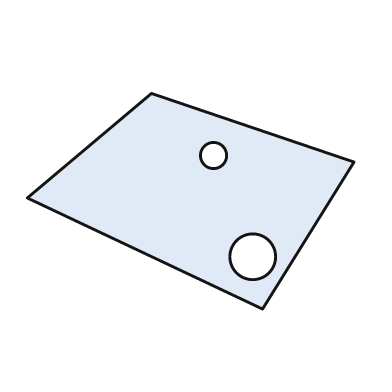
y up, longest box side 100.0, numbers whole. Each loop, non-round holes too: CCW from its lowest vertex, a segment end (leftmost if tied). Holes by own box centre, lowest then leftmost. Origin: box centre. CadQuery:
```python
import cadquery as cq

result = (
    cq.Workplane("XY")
    .moveTo(22.0, -33.0)
    .lineTo(50.0, 12.0)
    .lineTo(-12.0, 33.0)
    .lineTo(-50.0, 1.0)
    .close()
    .moveTo(19.0, -17.0)
    .circle(7.0)
    .moveTo(7.0, 14.0)
    .circle(4.0)
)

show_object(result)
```